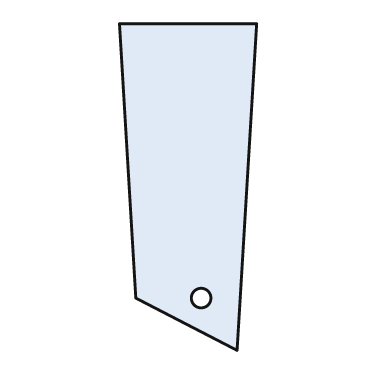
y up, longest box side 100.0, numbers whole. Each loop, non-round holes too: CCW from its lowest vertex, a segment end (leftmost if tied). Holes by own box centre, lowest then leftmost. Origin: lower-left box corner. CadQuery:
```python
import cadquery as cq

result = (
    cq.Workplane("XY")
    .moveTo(36.0, 0.0)
    .lineTo(42.0, 100.0)
    .lineTo(0.0, 100.0)
    .lineTo(5.0, 16.0)
    .close()
    .moveTo(25.0, 16.0)
    .circle(3.0)
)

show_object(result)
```